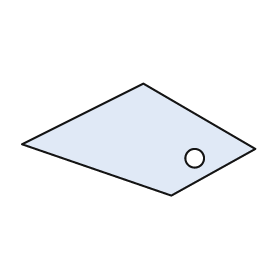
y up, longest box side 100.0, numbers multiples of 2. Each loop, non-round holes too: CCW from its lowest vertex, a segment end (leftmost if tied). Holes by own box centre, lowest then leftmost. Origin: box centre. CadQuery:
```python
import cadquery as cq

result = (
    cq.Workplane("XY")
    .moveTo(14.0, -24.0)
    .lineTo(50.0, -4.0)
    .lineTo(2.0, 24.0)
    .lineTo(-50.0, -2.0)
    .close()
    .moveTo(24.0, -8.0)
    .circle(4.0)
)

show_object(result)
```